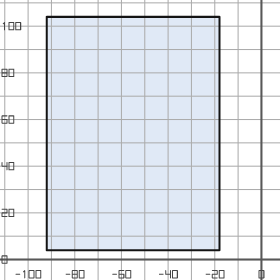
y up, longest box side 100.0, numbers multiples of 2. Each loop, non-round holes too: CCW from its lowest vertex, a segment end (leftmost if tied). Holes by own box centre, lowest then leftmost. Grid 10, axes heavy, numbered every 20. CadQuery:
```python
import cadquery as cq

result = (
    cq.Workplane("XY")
    .moveTo(-92.0, 4.0)
    .lineTo(-18.0, 4.0)
    .lineTo(-18.0, 104.0)
    .lineTo(-92.0, 104.0)
    .close()
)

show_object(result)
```